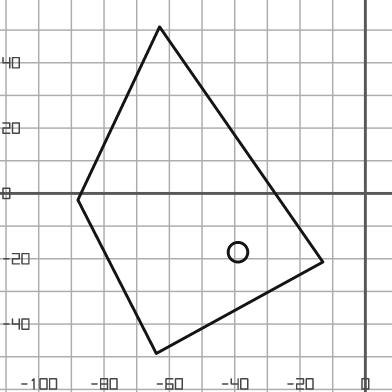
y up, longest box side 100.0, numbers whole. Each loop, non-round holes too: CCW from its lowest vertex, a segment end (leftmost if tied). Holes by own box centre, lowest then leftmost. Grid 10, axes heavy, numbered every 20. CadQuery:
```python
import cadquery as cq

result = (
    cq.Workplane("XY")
    .moveTo(-64.0, -49.0)
    .lineTo(-13.0, -21.0)
    .lineTo(-63.0, 51.0)
    .lineTo(-88.0, -2.0)
    .close()
    .moveTo(-39.0, -18.0)
    .circle(3.0)
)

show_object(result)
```